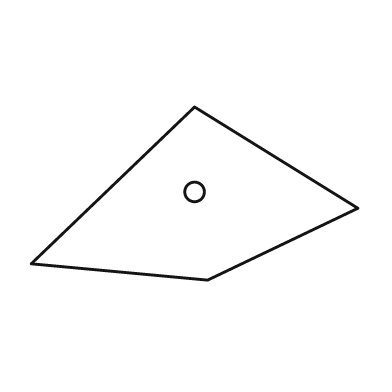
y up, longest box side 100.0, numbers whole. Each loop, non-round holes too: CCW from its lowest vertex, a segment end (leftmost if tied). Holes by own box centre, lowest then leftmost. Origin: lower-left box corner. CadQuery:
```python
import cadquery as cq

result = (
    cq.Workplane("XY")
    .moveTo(54.0, 0.0)
    .lineTo(100.0, 22.0)
    .lineTo(50.0, 53.0)
    .lineTo(0.0, 5.0)
    .close()
    .moveTo(50.0, 27.0)
    .circle(3.0)
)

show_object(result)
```